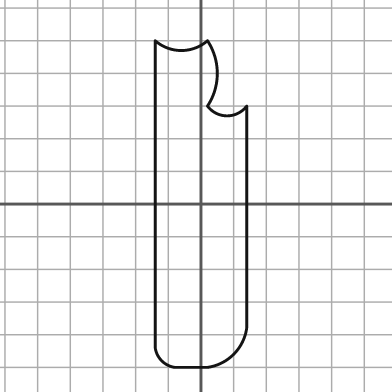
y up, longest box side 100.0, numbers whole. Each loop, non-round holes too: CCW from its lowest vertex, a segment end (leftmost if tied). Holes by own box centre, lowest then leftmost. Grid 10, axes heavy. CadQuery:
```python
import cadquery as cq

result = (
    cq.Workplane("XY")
    .moveTo(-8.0, -50.0)
    .lineTo(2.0, -50.0)
    .threePointArc((10.0, -46.0), (14.0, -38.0))
    .lineTo(14.0, 30.0)
    .threePointArc((8.0, 27.0), (2.0, 30.0))
    .threePointArc((5.0, 40.0), (2.0, 50.0))
    .threePointArc((-6.0, 47.0), (-14.0, 50.0))
    .lineTo(-14.0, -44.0)
    .threePointArc((-12.0, -48.0), (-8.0, -50.0))
    .close()
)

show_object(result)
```